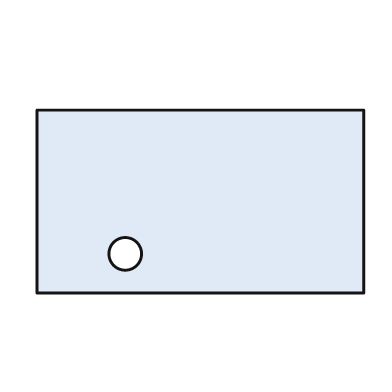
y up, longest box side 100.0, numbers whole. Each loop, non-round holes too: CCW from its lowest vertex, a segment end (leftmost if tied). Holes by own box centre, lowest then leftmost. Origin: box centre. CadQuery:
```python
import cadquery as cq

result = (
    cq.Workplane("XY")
    .moveTo(-50.0, -28.0)
    .lineTo(50.0, -28.0)
    .lineTo(50.0, 28.0)
    .lineTo(-50.0, 28.0)
    .close()
    .moveTo(-23.0, -16.0)
    .circle(5.0)
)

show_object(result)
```